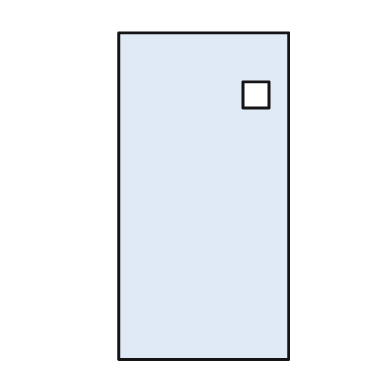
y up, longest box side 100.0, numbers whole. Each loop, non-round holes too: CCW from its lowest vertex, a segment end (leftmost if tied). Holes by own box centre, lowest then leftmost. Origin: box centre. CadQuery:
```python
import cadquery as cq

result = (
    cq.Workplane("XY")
    .moveTo(-26.0, -50.0)
    .lineTo(26.0, -50.0)
    .lineTo(26.0, 50.0)
    .lineTo(-26.0, 50.0)
    .close()
    .moveTo(12.0, 27.0)
    .lineTo(20.0, 27.0)
    .lineTo(20.0, 35.0)
    .lineTo(12.0, 35.0)
    .close()
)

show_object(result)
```